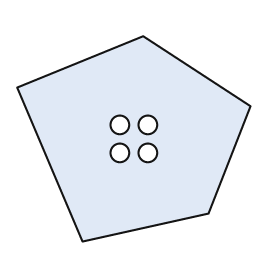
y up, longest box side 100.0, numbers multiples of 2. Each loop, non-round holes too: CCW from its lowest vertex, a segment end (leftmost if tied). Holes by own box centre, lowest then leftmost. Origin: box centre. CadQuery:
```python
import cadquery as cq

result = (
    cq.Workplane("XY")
    .moveTo(-22.0, -44.0)
    .lineTo(32.0, -32.0)
    .lineTo(50.0, 14.0)
    .lineTo(4.0, 44.0)
    .lineTo(-50.0, 22.0)
    .close()
    .moveTo(-6.0, -6.0)
    .circle(4.0)
    .moveTo(6.0, -6.0)
    .circle(4.0)
    .moveTo(-6.0, 6.0)
    .circle(4.0)
    .moveTo(6.0, 6.0)
    .circle(4.0)
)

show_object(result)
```